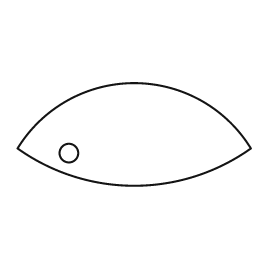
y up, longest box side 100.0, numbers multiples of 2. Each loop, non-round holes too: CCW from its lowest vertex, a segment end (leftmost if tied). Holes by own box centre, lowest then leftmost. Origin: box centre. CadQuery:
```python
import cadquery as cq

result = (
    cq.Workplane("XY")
    .moveTo(-50.0, -6.0)
    .threePointArc((0.0, -22.0), (50.0, -6.0))
    .threePointArc((0.0, 22.0), (-50.0, -6.0))
    .close()
    .moveTo(-28.0, -8.0)
    .circle(4.0)
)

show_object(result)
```